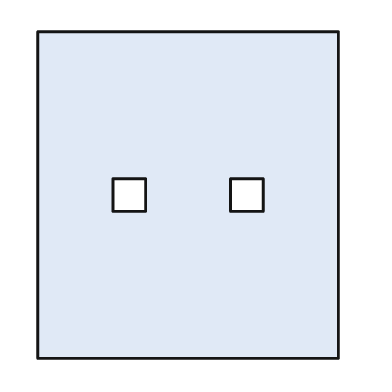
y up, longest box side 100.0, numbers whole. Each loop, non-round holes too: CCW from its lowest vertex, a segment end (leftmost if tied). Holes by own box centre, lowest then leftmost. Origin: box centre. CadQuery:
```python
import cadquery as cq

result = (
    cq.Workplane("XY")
    .moveTo(-46.0, -50.0)
    .lineTo(46.0, -50.0)
    .lineTo(46.0, 50.0)
    .lineTo(-46.0, 50.0)
    .close()
    .moveTo(-23.0, -5.0)
    .lineTo(-13.0, -5.0)
    .lineTo(-13.0, 5.0)
    .lineTo(-23.0, 5.0)
    .close()
    .moveTo(13.0, -5.0)
    .lineTo(23.0, -5.0)
    .lineTo(23.0, 5.0)
    .lineTo(13.0, 5.0)
    .close()
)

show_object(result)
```